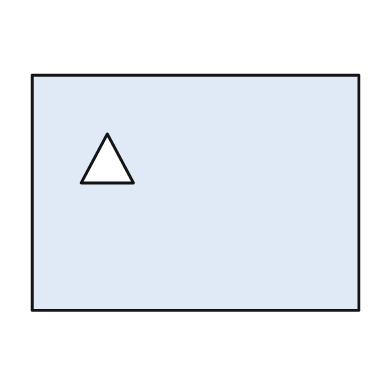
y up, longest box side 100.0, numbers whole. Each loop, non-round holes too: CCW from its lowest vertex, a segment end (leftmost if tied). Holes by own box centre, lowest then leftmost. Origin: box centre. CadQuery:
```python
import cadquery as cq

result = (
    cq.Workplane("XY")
    .moveTo(-50.0, -36.0)
    .lineTo(50.0, -36.0)
    .lineTo(50.0, 36.0)
    .lineTo(-50.0, 36.0)
    .close()
    .moveTo(-35.0, 3.0)
    .lineTo(-19.0, 3.0)
    .lineTo(-27.0, 18.0)
    .close()
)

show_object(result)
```